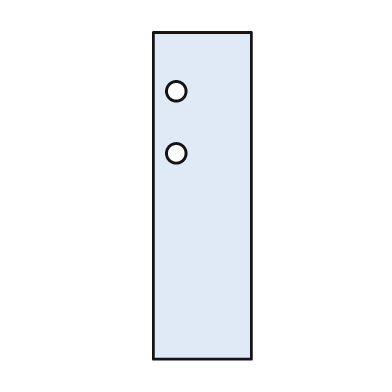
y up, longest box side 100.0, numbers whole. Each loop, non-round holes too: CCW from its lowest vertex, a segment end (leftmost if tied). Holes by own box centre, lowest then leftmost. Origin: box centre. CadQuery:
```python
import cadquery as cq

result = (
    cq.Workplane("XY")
    .moveTo(-15.0, -50.0)
    .lineTo(15.0, -50.0)
    .lineTo(15.0, 50.0)
    .lineTo(-15.0, 50.0)
    .close()
    .moveTo(-8.0, 13.0)
    .circle(3.0)
    .moveTo(-8.0, 32.0)
    .circle(3.0)
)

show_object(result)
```